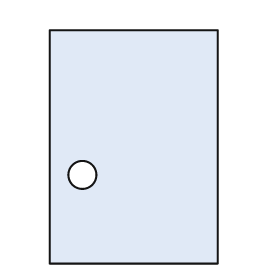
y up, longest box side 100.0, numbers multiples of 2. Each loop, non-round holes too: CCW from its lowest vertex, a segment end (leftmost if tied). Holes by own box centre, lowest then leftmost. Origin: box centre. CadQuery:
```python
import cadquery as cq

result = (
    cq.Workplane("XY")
    .moveTo(-36.0, -50.0)
    .lineTo(36.0, -50.0)
    .lineTo(36.0, 50.0)
    .lineTo(-36.0, 50.0)
    .close()
    .moveTo(-22.0, -12.0)
    .circle(6.0)
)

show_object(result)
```